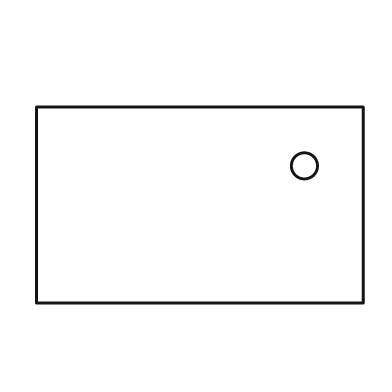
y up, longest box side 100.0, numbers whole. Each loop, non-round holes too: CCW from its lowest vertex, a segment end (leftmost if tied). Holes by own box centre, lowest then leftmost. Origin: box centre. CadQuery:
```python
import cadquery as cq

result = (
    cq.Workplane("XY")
    .moveTo(-50.0, -30.0)
    .lineTo(50.0, -30.0)
    .lineTo(50.0, 30.0)
    .lineTo(-50.0, 30.0)
    .close()
    .moveTo(32.0, 12.0)
    .circle(4.0)
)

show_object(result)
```